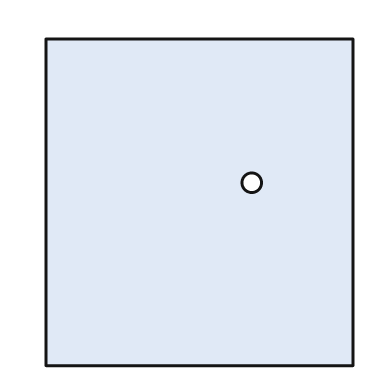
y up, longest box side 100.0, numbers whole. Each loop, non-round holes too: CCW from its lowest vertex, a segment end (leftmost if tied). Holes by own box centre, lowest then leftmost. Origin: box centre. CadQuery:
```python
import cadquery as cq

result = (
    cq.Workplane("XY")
    .moveTo(-47.0, -50.0)
    .lineTo(47.0, -50.0)
    .lineTo(47.0, 50.0)
    .lineTo(-47.0, 50.0)
    .close()
    .moveTo(16.0, 6.0)
    .circle(3.0)
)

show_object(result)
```